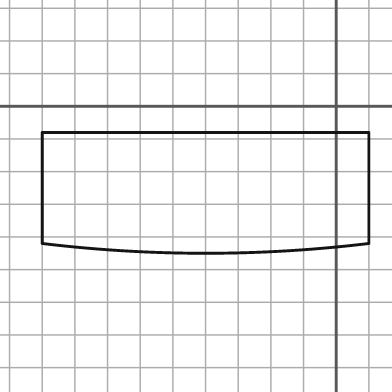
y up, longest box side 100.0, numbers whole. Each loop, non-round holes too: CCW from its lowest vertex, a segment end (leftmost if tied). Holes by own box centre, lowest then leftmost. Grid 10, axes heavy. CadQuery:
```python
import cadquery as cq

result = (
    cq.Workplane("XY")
    .moveTo(-90.0, -42.0)
    .threePointArc((-40.0, -45.0), (10.0, -42.0))
    .lineTo(10.0, -8.0)
    .lineTo(-90.0, -8.0)
    .close()
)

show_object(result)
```